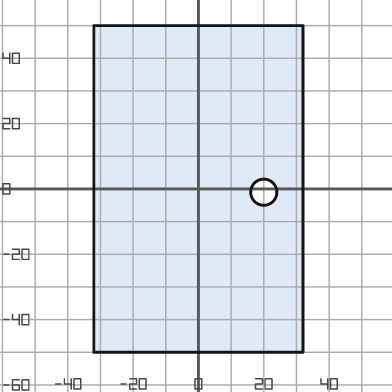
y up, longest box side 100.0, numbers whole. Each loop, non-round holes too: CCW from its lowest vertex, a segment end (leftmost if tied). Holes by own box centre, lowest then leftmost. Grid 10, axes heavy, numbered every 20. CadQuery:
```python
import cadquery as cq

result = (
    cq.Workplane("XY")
    .moveTo(-32.0, -50.0)
    .lineTo(32.0, -50.0)
    .lineTo(32.0, 50.0)
    .lineTo(-32.0, 50.0)
    .close()
    .moveTo(20.0, -1.0)
    .circle(4.0)
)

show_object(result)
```